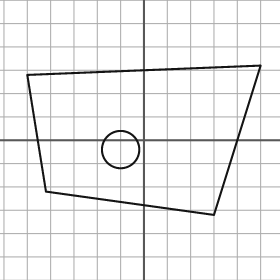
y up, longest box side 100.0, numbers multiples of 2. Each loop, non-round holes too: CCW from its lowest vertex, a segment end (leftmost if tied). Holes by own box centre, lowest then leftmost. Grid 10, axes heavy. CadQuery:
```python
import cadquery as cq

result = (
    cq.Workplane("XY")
    .moveTo(30.0, -32.0)
    .lineTo(50.0, 32.0)
    .lineTo(-50.0, 28.0)
    .lineTo(-42.0, -22.0)
    .close()
    .moveTo(-10.0, -4.0)
    .circle(8.0)
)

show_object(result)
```